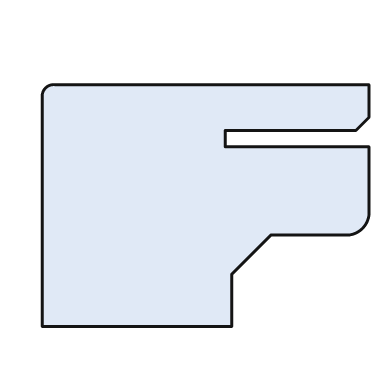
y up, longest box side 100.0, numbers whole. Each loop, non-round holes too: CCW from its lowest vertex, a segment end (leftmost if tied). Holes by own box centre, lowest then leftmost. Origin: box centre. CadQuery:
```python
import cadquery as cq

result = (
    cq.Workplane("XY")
    .moveTo(-50.0, -37.0)
    .lineTo(8.0, -37.0)
    .lineTo(8.0, -21.0)
    .lineTo(20.0, -9.0)
    .lineTo(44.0, -9.0)
    .threePointArc((48.0, -7.0), (50.0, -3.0))
    .lineTo(50.0, 18.0)
    .lineTo(6.0, 18.0)
    .lineTo(6.0, 23.0)
    .lineTo(46.0, 23.0)
    .lineTo(50.0, 27.0)
    .lineTo(50.0, 37.0)
    .lineTo(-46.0, 37.0)
    .threePointArc((-49.0, 36.0), (-50.0, 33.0))
    .close()
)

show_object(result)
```